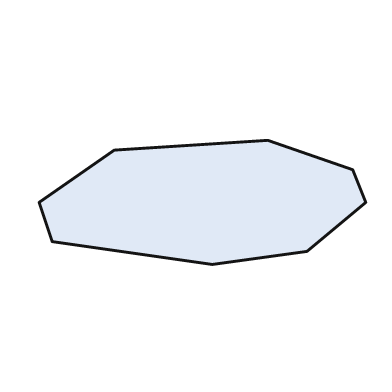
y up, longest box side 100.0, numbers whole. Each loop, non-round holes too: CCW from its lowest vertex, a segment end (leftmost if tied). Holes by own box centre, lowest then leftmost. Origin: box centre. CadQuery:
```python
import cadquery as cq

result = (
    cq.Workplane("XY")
    .moveTo(3.0, -19.0)
    .lineTo(32.0, -15.0)
    .lineTo(50.0, 0.0)
    .lineTo(46.0, 10.0)
    .lineTo(20.0, 19.0)
    .lineTo(-27.0, 16.0)
    .lineTo(-50.0, 0.0)
    .lineTo(-46.0, -12.0)
    .close()
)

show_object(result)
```